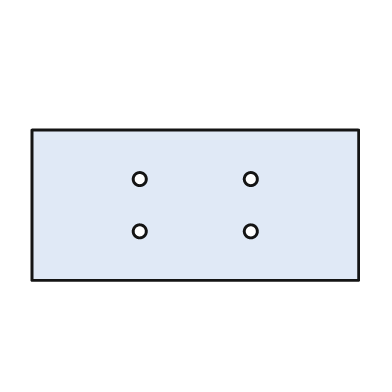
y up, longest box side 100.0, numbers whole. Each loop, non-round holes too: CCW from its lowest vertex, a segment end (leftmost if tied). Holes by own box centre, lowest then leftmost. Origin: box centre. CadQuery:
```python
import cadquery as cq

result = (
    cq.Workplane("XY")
    .moveTo(-50.0, -23.0)
    .lineTo(50.0, -23.0)
    .lineTo(50.0, 23.0)
    .lineTo(-50.0, 23.0)
    .close()
    .moveTo(-17.0, -8.0)
    .circle(2.0)
    .moveTo(17.0, -8.0)
    .circle(2.0)
    .moveTo(-17.0, 8.0)
    .circle(2.0)
    .moveTo(17.0, 8.0)
    .circle(2.0)
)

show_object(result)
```